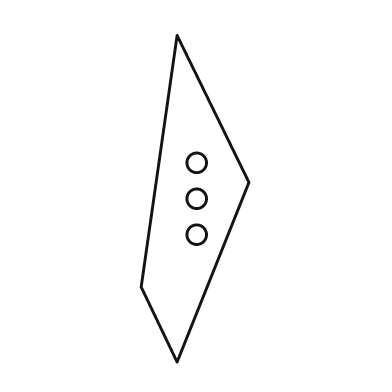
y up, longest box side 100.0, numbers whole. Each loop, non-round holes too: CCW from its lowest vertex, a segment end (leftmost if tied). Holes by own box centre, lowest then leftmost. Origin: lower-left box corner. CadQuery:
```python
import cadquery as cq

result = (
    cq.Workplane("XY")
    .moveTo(11.0, 0.0)
    .lineTo(33.0, 55.0)
    .lineTo(11.0, 100.0)
    .lineTo(0.0, 23.0)
    .close()
    .moveTo(17.0, 39.0)
    .circle(3.0)
    .moveTo(17.0, 50.0)
    .circle(3.0)
    .moveTo(17.0, 61.0)
    .circle(3.0)
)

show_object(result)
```